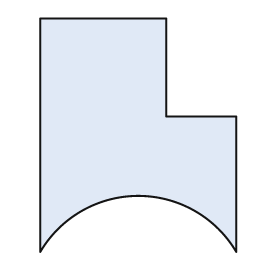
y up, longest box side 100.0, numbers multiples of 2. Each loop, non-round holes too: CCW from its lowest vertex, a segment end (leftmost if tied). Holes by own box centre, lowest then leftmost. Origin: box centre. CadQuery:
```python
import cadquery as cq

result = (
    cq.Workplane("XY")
    .moveTo(-42.0, -50.0)
    .threePointArc((0.0, -26.0), (42.0, -50.0))
    .lineTo(42.0, 8.0)
    .lineTo(12.0, 8.0)
    .lineTo(12.0, 50.0)
    .lineTo(-42.0, 50.0)
    .close()
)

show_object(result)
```